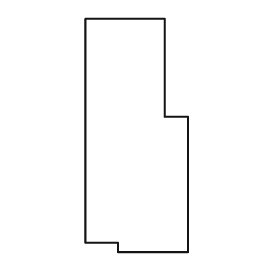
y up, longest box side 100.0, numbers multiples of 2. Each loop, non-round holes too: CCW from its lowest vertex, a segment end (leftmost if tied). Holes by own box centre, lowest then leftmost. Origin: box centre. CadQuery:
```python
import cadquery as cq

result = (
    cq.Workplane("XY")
    .moveTo(-8.0, -50.0)
    .lineTo(22.0, -50.0)
    .lineTo(22.0, 8.0)
    .lineTo(12.0, 8.0)
    .lineTo(12.0, 50.0)
    .lineTo(-22.0, 50.0)
    .lineTo(-22.0, -46.0)
    .lineTo(-8.0, -46.0)
    .close()
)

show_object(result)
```